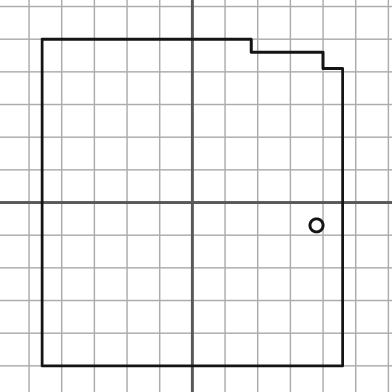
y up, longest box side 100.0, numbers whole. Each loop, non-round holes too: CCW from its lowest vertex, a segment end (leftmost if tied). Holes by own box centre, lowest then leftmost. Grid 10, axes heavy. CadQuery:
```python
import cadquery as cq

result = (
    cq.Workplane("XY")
    .moveTo(-46.0, -50.0)
    .lineTo(46.0, -50.0)
    .lineTo(46.0, 41.0)
    .lineTo(40.0, 41.0)
    .lineTo(40.0, 46.0)
    .lineTo(18.0, 46.0)
    .lineTo(18.0, 50.0)
    .lineTo(-46.0, 50.0)
    .close()
    .moveTo(38.0, -7.0)
    .circle(2.0)
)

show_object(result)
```